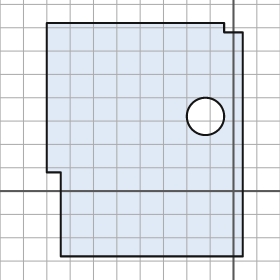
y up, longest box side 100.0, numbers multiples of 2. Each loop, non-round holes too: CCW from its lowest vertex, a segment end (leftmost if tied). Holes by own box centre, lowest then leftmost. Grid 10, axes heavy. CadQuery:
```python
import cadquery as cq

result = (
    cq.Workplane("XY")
    .moveTo(-74.0, -28.0)
    .lineTo(4.0, -28.0)
    .lineTo(4.0, 68.0)
    .lineTo(-4.0, 68.0)
    .lineTo(-4.0, 72.0)
    .lineTo(-80.0, 72.0)
    .lineTo(-80.0, 8.0)
    .lineTo(-74.0, 8.0)
    .close()
    .moveTo(-12.0, 32.0)
    .circle(8.0)
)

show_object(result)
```